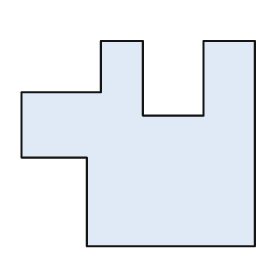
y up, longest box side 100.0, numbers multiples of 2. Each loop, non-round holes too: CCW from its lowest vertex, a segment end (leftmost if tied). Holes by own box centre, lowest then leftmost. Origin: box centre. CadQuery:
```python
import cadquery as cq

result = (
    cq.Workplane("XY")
    .moveTo(-22.0, -44.0)
    .lineTo(50.0, -44.0)
    .lineTo(50.0, 44.0)
    .lineTo(28.0, 44.0)
    .lineTo(28.0, 12.0)
    .lineTo(2.0, 12.0)
    .lineTo(2.0, 44.0)
    .lineTo(-16.0, 44.0)
    .lineTo(-16.0, 22.0)
    .lineTo(-50.0, 22.0)
    .lineTo(-50.0, -6.0)
    .lineTo(-22.0, -6.0)
    .close()
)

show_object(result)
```